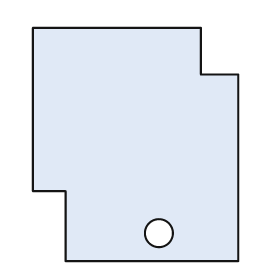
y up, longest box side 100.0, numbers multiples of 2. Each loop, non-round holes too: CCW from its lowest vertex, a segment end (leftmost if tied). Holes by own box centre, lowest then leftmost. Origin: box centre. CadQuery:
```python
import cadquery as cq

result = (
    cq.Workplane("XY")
    .moveTo(-30.0, -50.0)
    .lineTo(44.0, -50.0)
    .lineTo(44.0, 30.0)
    .lineTo(28.0, 30.0)
    .lineTo(28.0, 50.0)
    .lineTo(-44.0, 50.0)
    .lineTo(-44.0, -20.0)
    .lineTo(-30.0, -20.0)
    .close()
    .moveTo(10.0, -38.0)
    .circle(6.0)
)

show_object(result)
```